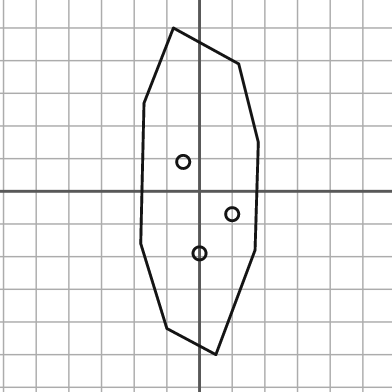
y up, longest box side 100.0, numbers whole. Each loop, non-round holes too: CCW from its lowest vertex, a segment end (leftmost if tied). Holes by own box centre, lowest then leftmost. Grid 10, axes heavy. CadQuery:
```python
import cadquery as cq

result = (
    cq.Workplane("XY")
    .moveTo(5.0, -50.0)
    .lineTo(17.0, -18.0)
    .lineTo(18.0, 15.0)
    .lineTo(12.0, 39.0)
    .lineTo(-8.0, 50.0)
    .lineTo(-17.0, 27.0)
    .lineTo(-18.0, -16.0)
    .lineTo(-10.0, -42.0)
    .close()
    .moveTo(0.0, -19.0)
    .circle(2.0)
    .moveTo(10.0, -7.0)
    .circle(2.0)
    .moveTo(-5.0, 9.0)
    .circle(2.0)
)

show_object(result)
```